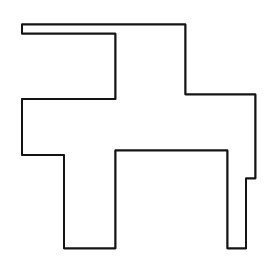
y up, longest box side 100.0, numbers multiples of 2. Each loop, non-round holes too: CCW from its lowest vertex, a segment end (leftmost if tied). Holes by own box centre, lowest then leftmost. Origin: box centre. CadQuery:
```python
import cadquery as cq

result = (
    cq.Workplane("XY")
    .moveTo(-32.0, -48.0)
    .lineTo(-10.0, -48.0)
    .lineTo(-10.0, -6.0)
    .lineTo(38.0, -6.0)
    .lineTo(38.0, -48.0)
    .lineTo(46.0, -48.0)
    .lineTo(46.0, -18.0)
    .lineTo(50.0, -18.0)
    .lineTo(50.0, 18.0)
    .lineTo(20.0, 18.0)
    .lineTo(20.0, 48.0)
    .lineTo(-50.0, 48.0)
    .lineTo(-50.0, 44.0)
    .lineTo(-10.0, 44.0)
    .lineTo(-10.0, 16.0)
    .lineTo(-50.0, 16.0)
    .lineTo(-50.0, -8.0)
    .lineTo(-32.0, -8.0)
    .close()
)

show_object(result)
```